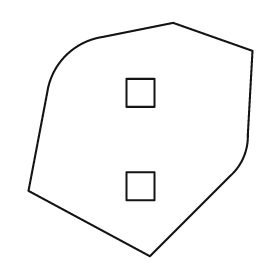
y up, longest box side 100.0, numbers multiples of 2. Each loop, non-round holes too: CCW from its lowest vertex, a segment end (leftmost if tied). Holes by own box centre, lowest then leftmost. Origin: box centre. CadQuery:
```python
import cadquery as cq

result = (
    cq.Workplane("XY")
    .moveTo(4.0, -50.0)
    .lineTo(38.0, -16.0)
    .threePointArc((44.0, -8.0), (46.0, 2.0))
    .lineTo(48.0, 38.0)
    .lineTo(14.0, 50.0)
    .lineTo(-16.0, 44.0)
    .threePointArc((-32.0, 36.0), (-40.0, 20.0))
    .lineTo(-48.0, -22.0)
    .close()
    .moveTo(-6.0, -26.0)
    .lineTo(6.0, -26.0)
    .lineTo(6.0, -14.0)
    .lineTo(-6.0, -14.0)
    .close()
    .moveTo(-6.0, 14.0)
    .lineTo(6.0, 14.0)
    .lineTo(6.0, 26.0)
    .lineTo(-6.0, 26.0)
    .close()
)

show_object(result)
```